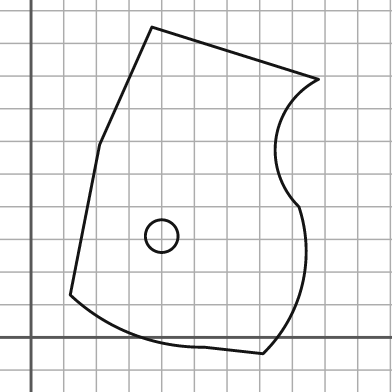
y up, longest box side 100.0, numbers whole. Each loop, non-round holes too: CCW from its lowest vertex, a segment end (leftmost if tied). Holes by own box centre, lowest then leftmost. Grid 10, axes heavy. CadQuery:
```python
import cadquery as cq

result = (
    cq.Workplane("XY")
    .moveTo(71.0, -5.0)
    .threePointArc((83.0, 16.0), (82.0, 40.0))
    .threePointArc((75.0, 61.0), (88.0, 79.0))
    .lineTo(37.0, 95.0)
    .lineTo(21.0, 59.0)
    .lineTo(12.0, 13.0)
    .threePointArc((31.0, 1.0), (53.0, -3.0))
    .close()
    .moveTo(40.0, 31.0)
    .circle(5.0)
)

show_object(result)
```